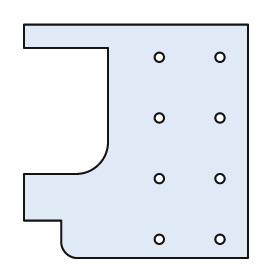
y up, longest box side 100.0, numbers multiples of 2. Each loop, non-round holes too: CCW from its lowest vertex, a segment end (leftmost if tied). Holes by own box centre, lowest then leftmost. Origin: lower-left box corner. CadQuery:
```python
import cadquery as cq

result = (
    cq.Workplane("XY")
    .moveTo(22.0, 0.0)
    .lineTo(96.0, 0.0)
    .lineTo(96.0, 100.0)
    .lineTo(0.0, 100.0)
    .lineTo(0.0, 90.0)
    .lineTo(36.0, 90.0)
    .lineTo(36.0, 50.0)
    .threePointArc((32.0, 40.0), (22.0, 36.0))
    .lineTo(0.0, 36.0)
    .lineTo(0.0, 16.0)
    .lineTo(16.0, 16.0)
    .lineTo(16.0, 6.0)
    .threePointArc((18.0, 2.0), (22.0, 0.0))
    .close()
    .moveTo(58.0, 8.0)
    .circle(2.0)
    .moveTo(84.0, 8.0)
    .circle(2.0)
    .moveTo(58.0, 34.0)
    .circle(2.0)
    .moveTo(84.0, 34.0)
    .circle(2.0)
    .moveTo(58.0, 60.0)
    .circle(2.0)
    .moveTo(84.0, 60.0)
    .circle(2.0)
    .moveTo(58.0, 86.0)
    .circle(2.0)
    .moveTo(84.0, 86.0)
    .circle(2.0)
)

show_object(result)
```